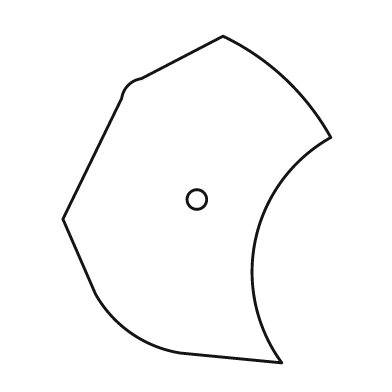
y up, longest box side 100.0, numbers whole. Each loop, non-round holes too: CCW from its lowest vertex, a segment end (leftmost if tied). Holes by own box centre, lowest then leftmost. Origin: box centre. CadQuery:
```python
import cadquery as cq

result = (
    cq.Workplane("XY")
    .moveTo(26.0, -50.0)
    .threePointArc((18.0, -12.0), (41.0, 19.0))
    .threePointArc((27.0, 37.0), (8.0, 50.0))
    .lineTo(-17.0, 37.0)
    .threePointArc((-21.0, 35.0), (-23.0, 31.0))
    .lineTo(-41.0, -6.0)
    .lineTo(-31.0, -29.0)
    .threePointArc((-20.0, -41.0), (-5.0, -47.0))
    .close()
    .moveTo(0.0, 0.0)
    .circle(3.0)
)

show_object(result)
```